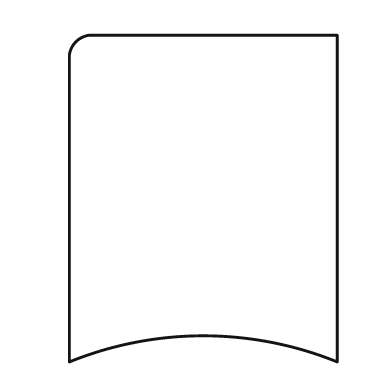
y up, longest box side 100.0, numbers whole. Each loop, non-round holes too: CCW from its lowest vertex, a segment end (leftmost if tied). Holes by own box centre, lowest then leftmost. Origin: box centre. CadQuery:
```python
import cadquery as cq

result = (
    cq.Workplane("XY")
    .moveTo(-41.0, -50.0)
    .threePointArc((0.0, -42.0), (41.0, -50.0))
    .lineTo(41.0, 50.0)
    .lineTo(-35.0, 50.0)
    .threePointArc((-39.0, 48.0), (-41.0, 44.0))
    .close()
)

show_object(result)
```